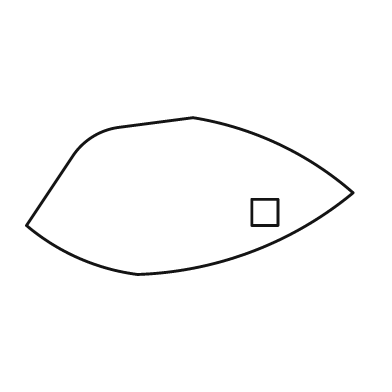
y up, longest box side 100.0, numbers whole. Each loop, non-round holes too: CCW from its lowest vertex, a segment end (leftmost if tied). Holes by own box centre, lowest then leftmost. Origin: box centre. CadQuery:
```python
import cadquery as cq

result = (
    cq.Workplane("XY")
    .moveTo(-16.0, -24.0)
    .threePointArc((19.0, -17.0), (50.0, 1.0))
    .threePointArc((27.0, 16.0), (1.0, 24.0))
    .lineTo(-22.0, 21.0)
    .threePointArc((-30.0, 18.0), (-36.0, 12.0))
    .lineTo(-50.0, -9.0)
    .threePointArc((-34.0, -19.0), (-16.0, -24.0))
    .close()
    .moveTo(19.0, -9.0)
    .lineTo(27.0, -9.0)
    .lineTo(27.0, -1.0)
    .lineTo(19.0, -1.0)
    .close()
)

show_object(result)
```